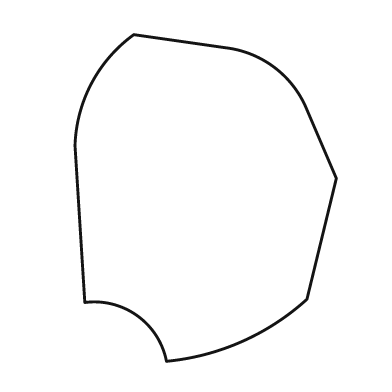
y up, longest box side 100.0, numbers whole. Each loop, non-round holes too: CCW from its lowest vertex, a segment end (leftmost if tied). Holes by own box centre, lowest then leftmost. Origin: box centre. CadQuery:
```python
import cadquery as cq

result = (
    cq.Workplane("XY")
    .moveTo(-12.0, -50.0)
    .threePointArc((11.0, -44.0), (31.0, -31.0))
    .lineTo(40.0, 6.0)
    .lineTo(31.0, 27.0)
    .threePointArc((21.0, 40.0), (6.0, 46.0))
    .lineTo(-22.0, 50.0)
    .threePointArc((-35.0, 35.0), (-40.0, 16.0))
    .lineTo(-37.0, -32.0)
    .threePointArc((-21.0, -36.0), (-12.0, -50.0))
    .close()
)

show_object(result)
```